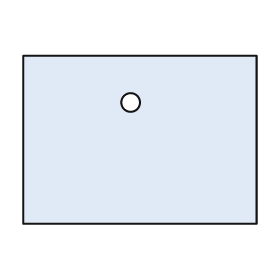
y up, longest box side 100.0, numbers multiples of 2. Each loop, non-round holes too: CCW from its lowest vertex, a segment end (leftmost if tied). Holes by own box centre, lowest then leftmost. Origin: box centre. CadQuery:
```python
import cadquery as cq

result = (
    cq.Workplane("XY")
    .moveTo(-50.0, -36.0)
    .lineTo(50.0, -36.0)
    .lineTo(50.0, 36.0)
    .lineTo(-50.0, 36.0)
    .close()
    .moveTo(-4.0, 16.0)
    .circle(4.0)
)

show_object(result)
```